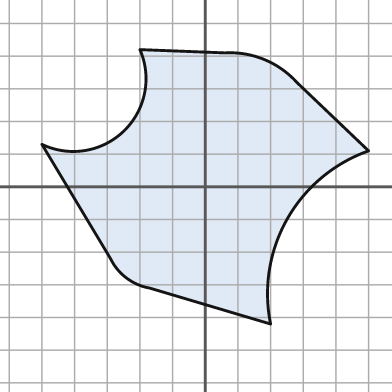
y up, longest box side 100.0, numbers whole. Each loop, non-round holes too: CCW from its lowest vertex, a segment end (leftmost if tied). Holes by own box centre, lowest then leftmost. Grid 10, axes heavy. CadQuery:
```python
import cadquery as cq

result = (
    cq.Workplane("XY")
    .moveTo(20.0, -42.0)
    .threePointArc((25.0, -10.0), (50.0, 11.0))
    .lineTo(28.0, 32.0)
    .threePointArc((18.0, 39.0), (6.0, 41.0))
    .lineTo(-20.0, 42.0)
    .threePointArc((-25.0, 17.0), (-50.0, 13.0))
    .lineTo(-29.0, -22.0)
    .threePointArc((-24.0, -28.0), (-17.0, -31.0))
    .close()
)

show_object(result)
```